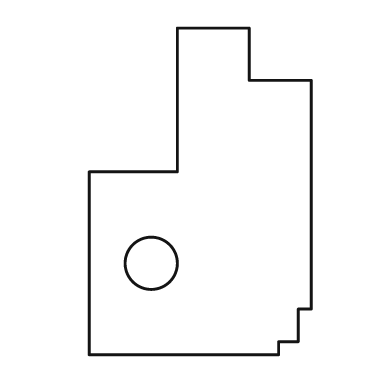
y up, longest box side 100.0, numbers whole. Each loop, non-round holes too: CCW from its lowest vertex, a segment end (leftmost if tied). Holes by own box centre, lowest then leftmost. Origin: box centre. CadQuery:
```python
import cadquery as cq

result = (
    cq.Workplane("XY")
    .moveTo(-34.0, -50.0)
    .lineTo(24.0, -50.0)
    .lineTo(24.0, -46.0)
    .lineTo(30.0, -46.0)
    .lineTo(30.0, -36.0)
    .lineTo(34.0, -36.0)
    .lineTo(34.0, 34.0)
    .lineTo(15.0, 34.0)
    .lineTo(15.0, 50.0)
    .lineTo(-7.0, 50.0)
    .lineTo(-7.0, 6.0)
    .lineTo(-34.0, 6.0)
    .close()
    .moveTo(-15.0, -22.0)
    .circle(8.0)
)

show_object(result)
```